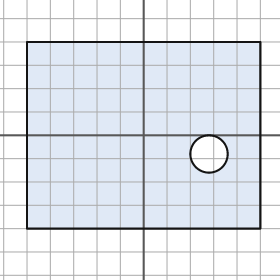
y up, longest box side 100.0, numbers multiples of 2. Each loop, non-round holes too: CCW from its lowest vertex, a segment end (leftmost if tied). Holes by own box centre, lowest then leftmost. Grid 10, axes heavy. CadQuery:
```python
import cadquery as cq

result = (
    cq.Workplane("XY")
    .moveTo(-50.0, -40.0)
    .lineTo(50.0, -40.0)
    .lineTo(50.0, 40.0)
    .lineTo(-50.0, 40.0)
    .close()
    .moveTo(28.0, -8.0)
    .circle(8.0)
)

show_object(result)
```